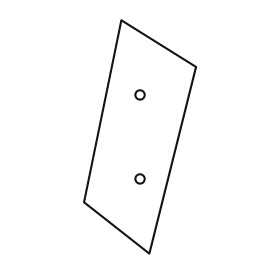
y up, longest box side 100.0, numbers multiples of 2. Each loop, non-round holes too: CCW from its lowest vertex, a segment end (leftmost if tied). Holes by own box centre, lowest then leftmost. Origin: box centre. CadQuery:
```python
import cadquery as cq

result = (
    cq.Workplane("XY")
    .moveTo(4.0, -50.0)
    .lineTo(24.0, 30.0)
    .lineTo(-8.0, 50.0)
    .lineTo(-24.0, -28.0)
    .close()
    .moveTo(0.0, -18.0)
    .circle(2.0)
    .moveTo(0.0, 18.0)
    .circle(2.0)
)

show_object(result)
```